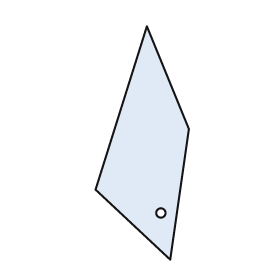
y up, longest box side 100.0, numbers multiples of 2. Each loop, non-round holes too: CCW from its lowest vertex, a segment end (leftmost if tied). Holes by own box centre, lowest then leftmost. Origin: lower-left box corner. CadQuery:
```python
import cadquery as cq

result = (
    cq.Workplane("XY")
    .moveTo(32.0, 0.0)
    .lineTo(40.0, 56.0)
    .lineTo(22.0, 100.0)
    .lineTo(0.0, 30.0)
    .close()
    .moveTo(28.0, 20.0)
    .circle(2.0)
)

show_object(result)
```